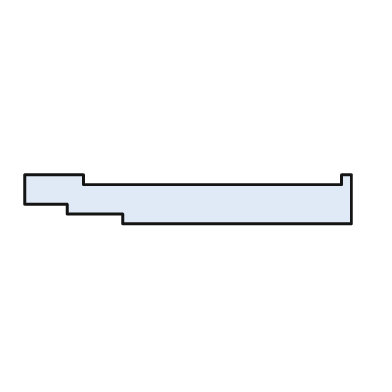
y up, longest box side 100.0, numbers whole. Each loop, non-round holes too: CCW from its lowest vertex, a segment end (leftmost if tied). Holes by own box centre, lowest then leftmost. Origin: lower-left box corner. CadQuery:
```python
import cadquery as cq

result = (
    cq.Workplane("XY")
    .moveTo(30.0, 0.0)
    .lineTo(100.0, 0.0)
    .lineTo(100.0, 15.0)
    .lineTo(97.0, 15.0)
    .lineTo(97.0, 12.0)
    .lineTo(18.0, 12.0)
    .lineTo(18.0, 15.0)
    .lineTo(0.0, 15.0)
    .lineTo(0.0, 6.0)
    .lineTo(13.0, 6.0)
    .lineTo(13.0, 3.0)
    .lineTo(30.0, 3.0)
    .close()
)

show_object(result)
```